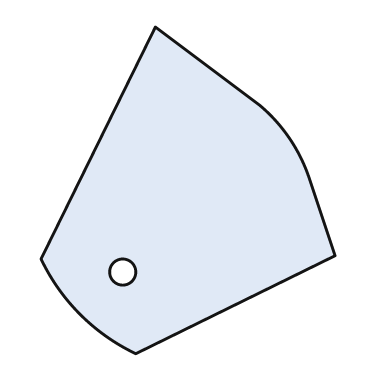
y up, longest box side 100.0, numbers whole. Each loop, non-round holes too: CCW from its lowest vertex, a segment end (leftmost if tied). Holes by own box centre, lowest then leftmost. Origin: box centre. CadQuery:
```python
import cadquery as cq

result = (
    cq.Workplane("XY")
    .moveTo(-16.0, -50.0)
    .lineTo(45.0, -20.0)
    .lineTo(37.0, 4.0)
    .threePointArc((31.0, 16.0), (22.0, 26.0))
    .lineTo(-10.0, 50.0)
    .lineTo(-45.0, -21.0)
    .threePointArc((-33.0, -38.0), (-16.0, -50.0))
    .close()
    .moveTo(-20.0, -25.0)
    .circle(4.0)
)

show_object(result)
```